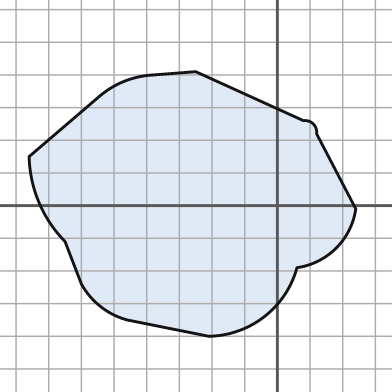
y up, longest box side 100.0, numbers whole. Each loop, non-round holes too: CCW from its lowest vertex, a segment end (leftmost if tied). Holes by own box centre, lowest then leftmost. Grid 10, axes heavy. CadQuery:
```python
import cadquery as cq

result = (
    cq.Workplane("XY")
    .moveTo(-21.0, -40.0)
    .threePointArc((-4.0, -34.0), (6.0, -19.0))
    .threePointArc((18.0, -13.0), (24.0, -1.0))
    .lineTo(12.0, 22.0)
    .threePointArc((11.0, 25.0), (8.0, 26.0))
    .lineTo(-25.0, 41.0)
    .lineTo(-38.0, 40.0)
    .threePointArc((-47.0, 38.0), (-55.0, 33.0))
    .lineTo(-76.0, 15.0)
    .threePointArc((-73.0, 1.0), (-65.0, -11.0))
    .lineTo(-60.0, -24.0)
    .threePointArc((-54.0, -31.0), (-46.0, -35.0))
    .close()
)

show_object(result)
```